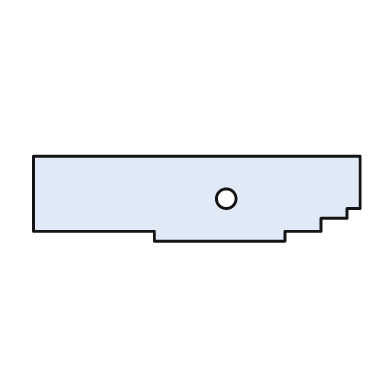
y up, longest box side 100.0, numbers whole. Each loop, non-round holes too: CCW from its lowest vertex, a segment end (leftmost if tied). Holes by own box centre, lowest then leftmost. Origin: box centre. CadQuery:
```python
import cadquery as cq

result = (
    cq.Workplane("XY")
    .moveTo(-13.0, -13.0)
    .lineTo(27.0, -13.0)
    .lineTo(27.0, -10.0)
    .lineTo(38.0, -10.0)
    .lineTo(38.0, -6.0)
    .lineTo(46.0, -6.0)
    .lineTo(46.0, -3.0)
    .lineTo(50.0, -3.0)
    .lineTo(50.0, 13.0)
    .lineTo(-50.0, 13.0)
    .lineTo(-50.0, -10.0)
    .lineTo(-13.0, -10.0)
    .close()
    .moveTo(9.0, 0.0)
    .circle(3.0)
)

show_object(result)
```